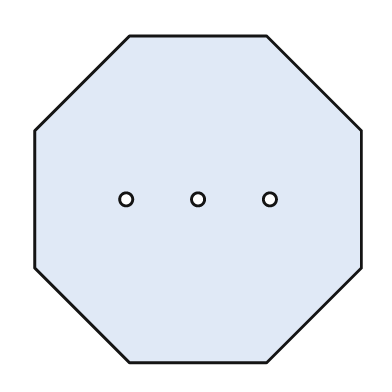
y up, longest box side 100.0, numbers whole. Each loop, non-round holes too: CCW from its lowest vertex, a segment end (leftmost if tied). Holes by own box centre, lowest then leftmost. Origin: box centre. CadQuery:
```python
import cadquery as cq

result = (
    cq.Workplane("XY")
    .moveTo(-21.0, -50.0)
    .lineTo(21.0, -50.0)
    .lineTo(50.0, -21.0)
    .lineTo(50.0, 21.0)
    .lineTo(21.0, 50.0)
    .lineTo(-21.0, 50.0)
    .lineTo(-50.0, 21.0)
    .lineTo(-50.0, -21.0)
    .close()
    .moveTo(-22.0, 0.0)
    .circle(2.0)
    .moveTo(0.0, 0.0)
    .circle(2.0)
    .moveTo(22.0, 0.0)
    .circle(2.0)
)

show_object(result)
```